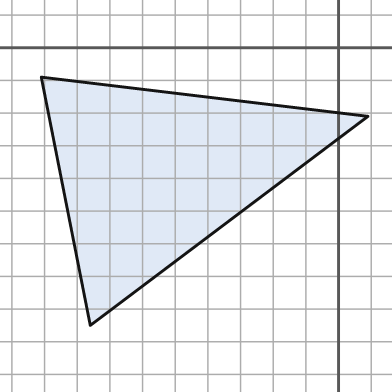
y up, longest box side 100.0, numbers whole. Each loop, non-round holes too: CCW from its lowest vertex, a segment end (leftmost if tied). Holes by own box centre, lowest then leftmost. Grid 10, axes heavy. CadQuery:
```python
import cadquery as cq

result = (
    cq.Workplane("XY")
    .moveTo(-76.0, -85.0)
    .lineTo(9.0, -21.0)
    .lineTo(-91.0, -9.0)
    .close()
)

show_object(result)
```